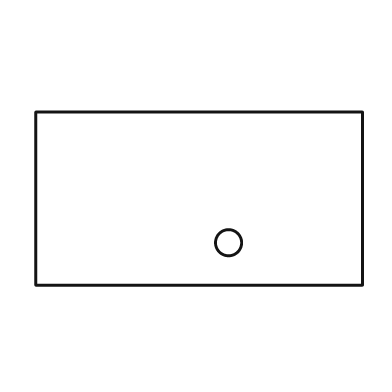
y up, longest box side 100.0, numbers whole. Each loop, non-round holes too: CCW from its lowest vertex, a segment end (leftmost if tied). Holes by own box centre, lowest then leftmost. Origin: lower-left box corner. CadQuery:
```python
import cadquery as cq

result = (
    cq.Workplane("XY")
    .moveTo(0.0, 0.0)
    .lineTo(100.0, 0.0)
    .lineTo(100.0, 53.0)
    .lineTo(0.0, 53.0)
    .close()
    .moveTo(59.0, 13.0)
    .circle(4.0)
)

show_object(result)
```